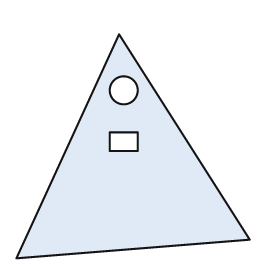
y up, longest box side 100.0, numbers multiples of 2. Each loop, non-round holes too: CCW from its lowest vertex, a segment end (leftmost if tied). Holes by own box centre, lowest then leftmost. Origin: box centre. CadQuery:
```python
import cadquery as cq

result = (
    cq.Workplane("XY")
    .moveTo(-50.0, -48.0)
    .lineTo(50.0, -40.0)
    .lineTo(-6.0, 48.0)
    .close()
    .moveTo(-10.0, -2.0)
    .lineTo(2.0, -2.0)
    .lineTo(2.0, 6.0)
    .lineTo(-10.0, 6.0)
    .close()
    .moveTo(-4.0, 24.0)
    .circle(6.0)
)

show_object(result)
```